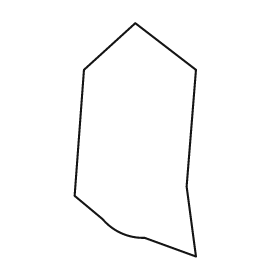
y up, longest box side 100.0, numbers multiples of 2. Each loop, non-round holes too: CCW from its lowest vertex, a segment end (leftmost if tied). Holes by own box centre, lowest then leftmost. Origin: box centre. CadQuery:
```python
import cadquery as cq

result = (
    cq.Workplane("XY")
    .moveTo(26.0, -50.0)
    .lineTo(22.0, -20.0)
    .lineTo(26.0, 30.0)
    .lineTo(0.0, 50.0)
    .lineTo(-22.0, 30.0)
    .lineTo(-26.0, -24.0)
    .lineTo(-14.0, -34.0)
    .threePointArc((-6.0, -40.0), (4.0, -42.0))
    .close()
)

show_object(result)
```